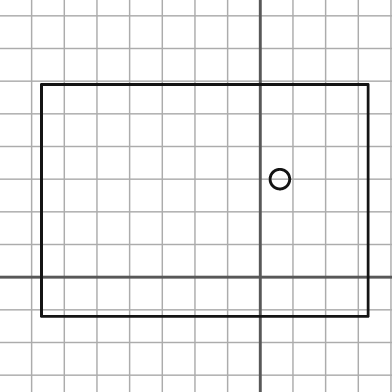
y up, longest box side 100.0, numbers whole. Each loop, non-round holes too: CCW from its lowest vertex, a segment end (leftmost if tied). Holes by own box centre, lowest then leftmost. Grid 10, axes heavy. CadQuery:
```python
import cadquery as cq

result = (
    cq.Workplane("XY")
    .moveTo(-67.0, -12.0)
    .lineTo(33.0, -12.0)
    .lineTo(33.0, 59.0)
    .lineTo(-67.0, 59.0)
    .close()
    .moveTo(6.0, 30.0)
    .circle(3.0)
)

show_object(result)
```